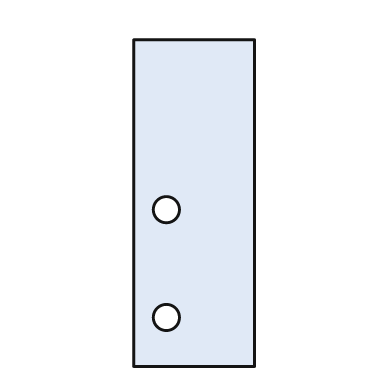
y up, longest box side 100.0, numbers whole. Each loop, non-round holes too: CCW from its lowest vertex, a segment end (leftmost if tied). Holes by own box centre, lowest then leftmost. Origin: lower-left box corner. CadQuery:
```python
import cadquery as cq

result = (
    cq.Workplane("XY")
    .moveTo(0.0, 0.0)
    .lineTo(37.0, 0.0)
    .lineTo(37.0, 100.0)
    .lineTo(0.0, 100.0)
    .close()
    .moveTo(10.0, 15.0)
    .circle(4.0)
    .moveTo(10.0, 48.0)
    .circle(4.0)
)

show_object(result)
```